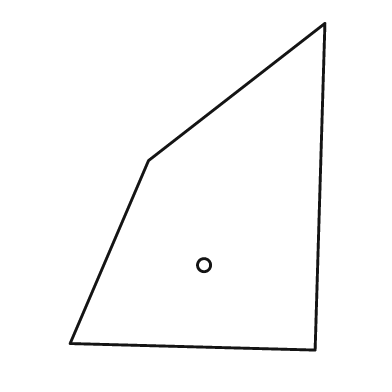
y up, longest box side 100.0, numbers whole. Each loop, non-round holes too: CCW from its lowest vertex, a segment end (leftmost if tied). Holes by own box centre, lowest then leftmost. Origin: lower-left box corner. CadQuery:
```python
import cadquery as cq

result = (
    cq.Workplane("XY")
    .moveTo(75.0, 0.0)
    .lineTo(78.0, 100.0)
    .lineTo(24.0, 58.0)
    .lineTo(0.0, 2.0)
    .close()
    .moveTo(41.0, 26.0)
    .circle(2.0)
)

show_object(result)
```